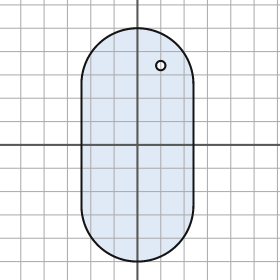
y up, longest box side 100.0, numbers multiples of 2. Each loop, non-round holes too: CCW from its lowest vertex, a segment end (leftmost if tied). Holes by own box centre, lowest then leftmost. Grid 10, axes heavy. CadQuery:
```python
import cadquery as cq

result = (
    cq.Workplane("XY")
    .moveTo(-24.0, -26.0)
    .threePointArc((0.0, -50.0), (24.0, -26.0))
    .lineTo(24.0, 26.0)
    .threePointArc((0.0, 50.0), (-24.0, 26.0))
    .close()
    .moveTo(10.0, 34.0)
    .circle(2.0)
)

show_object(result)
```